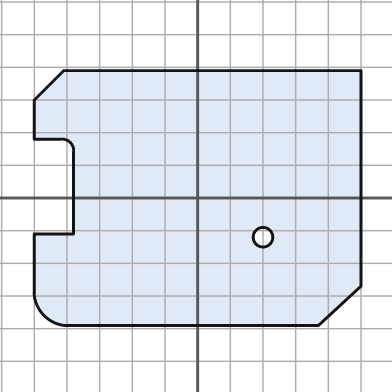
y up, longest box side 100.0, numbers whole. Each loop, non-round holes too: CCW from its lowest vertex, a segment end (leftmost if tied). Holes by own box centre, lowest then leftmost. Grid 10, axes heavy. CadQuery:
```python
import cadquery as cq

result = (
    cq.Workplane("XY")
    .moveTo(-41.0, -39.0)
    .lineTo(37.0, -39.0)
    .lineTo(50.0, -27.0)
    .lineTo(50.0, 39.0)
    .lineTo(-41.0, 39.0)
    .lineTo(-50.0, 30.0)
    .lineTo(-50.0, 18.0)
    .lineTo(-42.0, 18.0)
    .threePointArc((-39.0, 17.0), (-38.0, 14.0))
    .lineTo(-38.0, -11.0)
    .lineTo(-50.0, -11.0)
    .lineTo(-50.0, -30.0)
    .threePointArc((-47.0, -36.0), (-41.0, -39.0))
    .close()
    .moveTo(20.0, -12.0)
    .circle(3.0)
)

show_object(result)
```